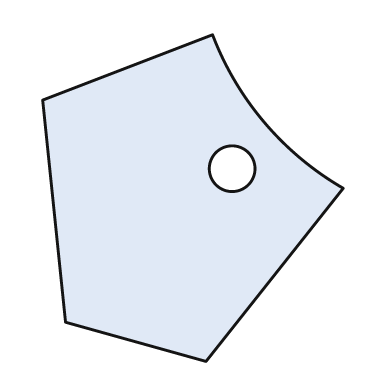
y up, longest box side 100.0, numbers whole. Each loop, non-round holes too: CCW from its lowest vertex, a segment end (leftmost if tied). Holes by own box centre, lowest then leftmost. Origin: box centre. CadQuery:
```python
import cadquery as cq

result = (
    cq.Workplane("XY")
    .moveTo(4.0, -50.0)
    .lineTo(46.0, 3.0)
    .threePointArc((22.0, 23.0), (6.0, 50.0))
    .lineTo(-46.0, 30.0)
    .lineTo(-39.0, -38.0)
    .close()
    .moveTo(12.0, 9.0)
    .circle(7.0)
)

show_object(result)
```